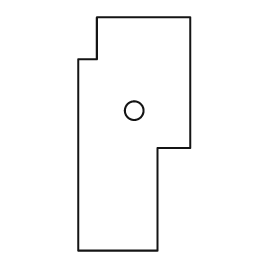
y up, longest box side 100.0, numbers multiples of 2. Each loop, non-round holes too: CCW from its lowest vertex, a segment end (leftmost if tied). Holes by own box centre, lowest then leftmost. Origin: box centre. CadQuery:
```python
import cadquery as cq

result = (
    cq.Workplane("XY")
    .moveTo(-24.0, -50.0)
    .lineTo(10.0, -50.0)
    .lineTo(10.0, -6.0)
    .lineTo(24.0, -6.0)
    .lineTo(24.0, 50.0)
    .lineTo(-16.0, 50.0)
    .lineTo(-16.0, 32.0)
    .lineTo(-24.0, 32.0)
    .close()
    .moveTo(0.0, 10.0)
    .circle(4.0)
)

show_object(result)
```